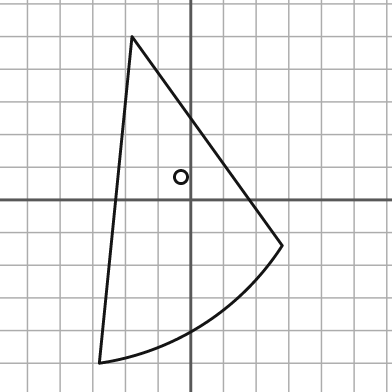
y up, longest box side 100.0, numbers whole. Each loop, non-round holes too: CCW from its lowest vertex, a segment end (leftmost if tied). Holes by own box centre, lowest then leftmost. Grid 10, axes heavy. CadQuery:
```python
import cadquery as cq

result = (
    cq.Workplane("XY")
    .moveTo(-28.0, -50.0)
    .threePointArc((4.0, -38.0), (28.0, -14.0))
    .lineTo(-18.0, 50.0)
    .close()
    .moveTo(-3.0, 7.0)
    .circle(2.0)
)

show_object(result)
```